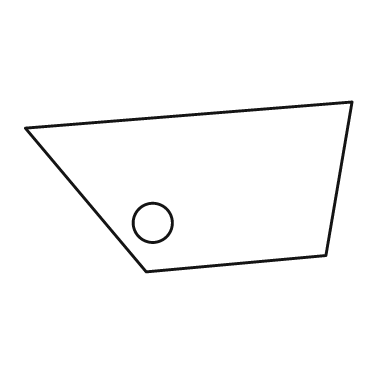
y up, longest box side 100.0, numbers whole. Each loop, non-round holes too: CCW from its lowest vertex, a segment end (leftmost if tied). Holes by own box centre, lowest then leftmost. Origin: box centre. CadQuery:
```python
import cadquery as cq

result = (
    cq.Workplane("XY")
    .moveTo(-13.0, -26.0)
    .lineTo(42.0, -21.0)
    .lineTo(50.0, 26.0)
    .lineTo(-50.0, 18.0)
    .close()
    .moveTo(-11.0, -11.0)
    .circle(6.0)
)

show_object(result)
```